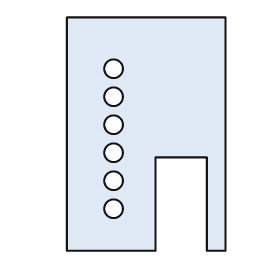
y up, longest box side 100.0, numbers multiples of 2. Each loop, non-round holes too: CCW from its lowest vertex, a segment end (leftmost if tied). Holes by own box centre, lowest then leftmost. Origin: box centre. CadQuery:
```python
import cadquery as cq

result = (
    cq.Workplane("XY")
    .moveTo(-34.0, -50.0)
    .lineTo(4.0, -50.0)
    .lineTo(4.0, -10.0)
    .lineTo(26.0, -10.0)
    .lineTo(26.0, -50.0)
    .lineTo(34.0, -50.0)
    .lineTo(34.0, 50.0)
    .lineTo(-34.0, 50.0)
    .close()
    .moveTo(-14.0, -32.0)
    .circle(4.0)
    .moveTo(-14.0, -20.0)
    .circle(4.0)
    .moveTo(-14.0, -8.0)
    .circle(4.0)
    .moveTo(-14.0, 4.0)
    .circle(4.0)
    .moveTo(-14.0, 16.0)
    .circle(4.0)
    .moveTo(-14.0, 28.0)
    .circle(4.0)
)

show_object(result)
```